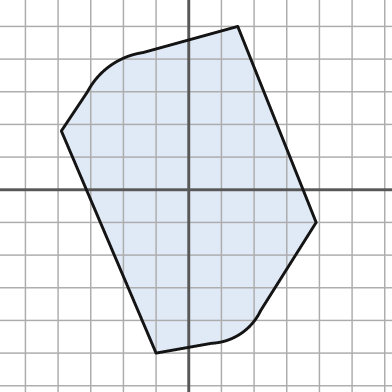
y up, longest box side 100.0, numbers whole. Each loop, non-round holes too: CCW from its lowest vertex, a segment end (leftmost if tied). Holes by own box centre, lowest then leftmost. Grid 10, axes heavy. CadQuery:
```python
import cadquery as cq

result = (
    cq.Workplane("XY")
    .moveTo(-10.0, -50.0)
    .lineTo(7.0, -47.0)
    .threePointArc((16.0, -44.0), (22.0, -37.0))
    .lineTo(39.0, -10.0)
    .lineTo(15.0, 50.0)
    .lineTo(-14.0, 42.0)
    .threePointArc((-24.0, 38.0), (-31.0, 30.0))
    .lineTo(-39.0, 18.0)
    .close()
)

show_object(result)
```